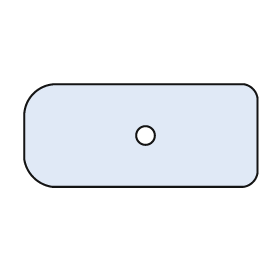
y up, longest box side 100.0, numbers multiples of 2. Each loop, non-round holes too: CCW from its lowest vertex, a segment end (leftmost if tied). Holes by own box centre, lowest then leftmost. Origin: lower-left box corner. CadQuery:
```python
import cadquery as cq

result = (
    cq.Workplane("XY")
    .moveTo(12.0, 0.0)
    .lineTo(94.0, 0.0)
    .threePointArc((98.0, 2.0), (100.0, 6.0))
    .lineTo(100.0, 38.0)
    .threePointArc((98.0, 42.0), (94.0, 44.0))
    .lineTo(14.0, 44.0)
    .threePointArc((4.0, 40.0), (0.0, 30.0))
    .lineTo(0.0, 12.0)
    .threePointArc((4.0, 4.0), (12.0, 0.0))
    .close()
    .moveTo(52.0, 22.0)
    .circle(4.0)
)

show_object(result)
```